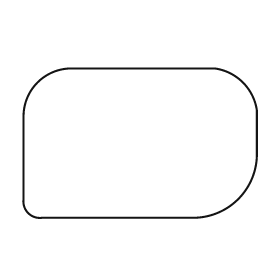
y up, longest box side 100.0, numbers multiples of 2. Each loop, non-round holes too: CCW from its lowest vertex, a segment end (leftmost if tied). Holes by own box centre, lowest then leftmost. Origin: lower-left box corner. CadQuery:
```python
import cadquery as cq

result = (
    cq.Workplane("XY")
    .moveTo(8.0, 0.0)
    .lineTo(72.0, 0.0)
    .threePointArc((92.0, 8.0), (100.0, 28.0))
    .lineTo(100.0, 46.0)
    .threePointArc((94.0, 58.0), (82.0, 64.0))
    .lineTo(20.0, 64.0)
    .threePointArc((6.0, 58.0), (0.0, 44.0))
    .lineTo(0.0, 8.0)
    .threePointArc((2.0, 2.0), (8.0, 0.0))
    .close()
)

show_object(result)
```